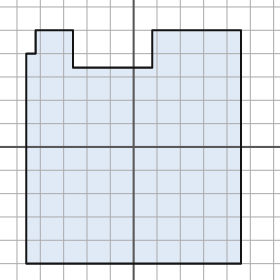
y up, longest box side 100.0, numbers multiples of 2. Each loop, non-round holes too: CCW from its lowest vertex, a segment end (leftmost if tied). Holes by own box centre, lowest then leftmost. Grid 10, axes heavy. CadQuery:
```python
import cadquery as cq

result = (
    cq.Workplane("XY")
    .moveTo(-46.0, -50.0)
    .lineTo(46.0, -50.0)
    .lineTo(46.0, 50.0)
    .lineTo(8.0, 50.0)
    .lineTo(8.0, 34.0)
    .lineTo(-26.0, 34.0)
    .lineTo(-26.0, 50.0)
    .lineTo(-42.0, 50.0)
    .lineTo(-42.0, 40.0)
    .lineTo(-46.0, 40.0)
    .close()
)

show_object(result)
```